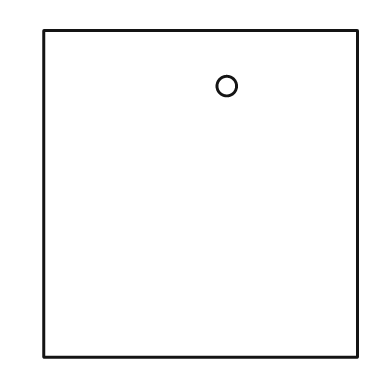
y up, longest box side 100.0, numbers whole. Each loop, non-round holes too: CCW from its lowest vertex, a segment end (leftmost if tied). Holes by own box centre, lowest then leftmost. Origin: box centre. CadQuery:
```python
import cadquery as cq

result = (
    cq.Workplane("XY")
    .moveTo(-48.0, -50.0)
    .lineTo(48.0, -50.0)
    .lineTo(48.0, 50.0)
    .lineTo(-48.0, 50.0)
    .close()
    .moveTo(8.0, 33.0)
    .circle(3.0)
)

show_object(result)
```